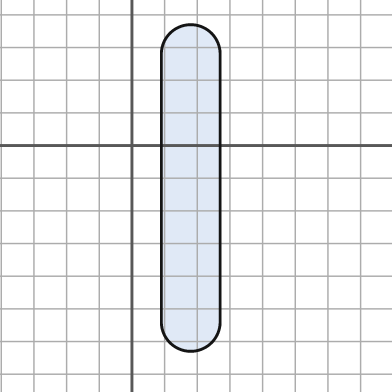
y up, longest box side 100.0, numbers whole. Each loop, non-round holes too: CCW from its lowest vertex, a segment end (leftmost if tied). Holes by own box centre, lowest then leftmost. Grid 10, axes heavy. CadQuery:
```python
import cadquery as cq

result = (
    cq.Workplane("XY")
    .moveTo(9.0, -54.0)
    .threePointArc((18.0, -63.0), (27.0, -54.0))
    .lineTo(27.0, 28.0)
    .threePointArc((18.0, 37.0), (9.0, 28.0))
    .close()
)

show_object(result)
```